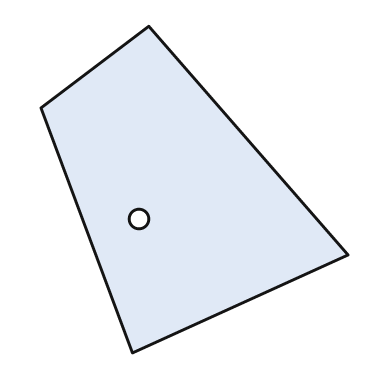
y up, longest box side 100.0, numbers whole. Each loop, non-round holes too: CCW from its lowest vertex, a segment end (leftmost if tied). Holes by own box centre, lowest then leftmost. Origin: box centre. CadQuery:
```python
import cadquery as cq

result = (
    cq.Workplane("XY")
    .moveTo(-19.0, -50.0)
    .lineTo(47.0, -20.0)
    .lineTo(-14.0, 50.0)
    .lineTo(-47.0, 25.0)
    .close()
    .moveTo(-17.0, -9.0)
    .circle(3.0)
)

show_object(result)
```